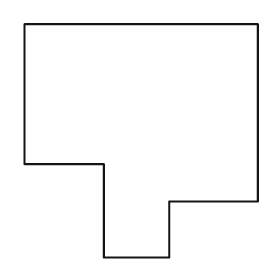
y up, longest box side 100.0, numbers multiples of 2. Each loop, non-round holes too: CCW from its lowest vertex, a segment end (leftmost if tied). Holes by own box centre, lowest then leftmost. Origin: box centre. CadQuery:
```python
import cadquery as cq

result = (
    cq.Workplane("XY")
    .moveTo(-16.0, -50.0)
    .lineTo(12.0, -50.0)
    .lineTo(12.0, -26.0)
    .lineTo(50.0, -26.0)
    .lineTo(50.0, 50.0)
    .lineTo(-50.0, 50.0)
    .lineTo(-50.0, -10.0)
    .lineTo(-16.0, -10.0)
    .close()
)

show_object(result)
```